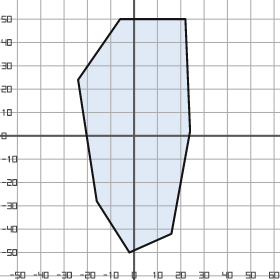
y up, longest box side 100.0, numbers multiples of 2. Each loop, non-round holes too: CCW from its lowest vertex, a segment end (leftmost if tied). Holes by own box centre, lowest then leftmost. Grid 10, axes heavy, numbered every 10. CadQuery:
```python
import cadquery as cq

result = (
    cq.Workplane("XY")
    .moveTo(-2.0, -50.0)
    .lineTo(16.0, -42.0)
    .lineTo(24.0, 2.0)
    .lineTo(22.0, 50.0)
    .lineTo(-6.0, 50.0)
    .lineTo(-24.0, 24.0)
    .lineTo(-16.0, -28.0)
    .close()
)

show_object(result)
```